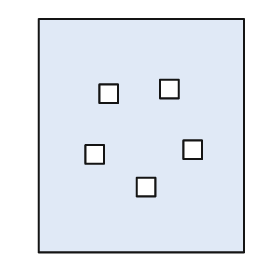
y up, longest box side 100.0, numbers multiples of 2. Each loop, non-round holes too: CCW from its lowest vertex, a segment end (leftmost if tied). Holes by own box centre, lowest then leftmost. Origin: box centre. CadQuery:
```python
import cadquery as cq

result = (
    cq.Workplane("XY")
    .moveTo(-44.0, -50.0)
    .lineTo(44.0, -50.0)
    .lineTo(44.0, 50.0)
    .lineTo(-44.0, 50.0)
    .close()
    .moveTo(-2.0, -26.0)
    .lineTo(6.0, -26.0)
    .lineTo(6.0, -18.0)
    .lineTo(-2.0, -18.0)
    .close()
    .moveTo(-24.0, -12.0)
    .lineTo(-16.0, -12.0)
    .lineTo(-16.0, -4.0)
    .lineTo(-24.0, -4.0)
    .close()
    .moveTo(18.0, -10.0)
    .lineTo(26.0, -10.0)
    .lineTo(26.0, -2.0)
    .lineTo(18.0, -2.0)
    .close()
    .moveTo(-18.0, 14.0)
    .lineTo(-10.0, 14.0)
    .lineTo(-10.0, 22.0)
    .lineTo(-18.0, 22.0)
    .close()
    .moveTo(8.0, 16.0)
    .lineTo(16.0, 16.0)
    .lineTo(16.0, 24.0)
    .lineTo(8.0, 24.0)
    .close()
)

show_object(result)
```